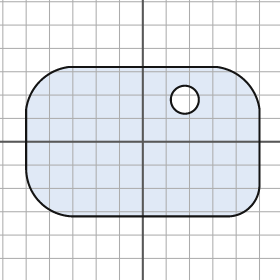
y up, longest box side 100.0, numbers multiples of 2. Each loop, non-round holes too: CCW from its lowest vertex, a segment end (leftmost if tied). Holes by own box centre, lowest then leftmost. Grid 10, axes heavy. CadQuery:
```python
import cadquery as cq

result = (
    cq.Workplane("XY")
    .moveTo(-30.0, -32.0)
    .lineTo(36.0, -32.0)
    .threePointArc((46.0, -28.0), (50.0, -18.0))
    .lineTo(50.0, 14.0)
    .threePointArc((44.0, 26.0), (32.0, 32.0))
    .lineTo(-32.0, 32.0)
    .threePointArc((-44.0, 26.0), (-50.0, 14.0))
    .lineTo(-50.0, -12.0)
    .threePointArc((-44.0, -26.0), (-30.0, -32.0))
    .close()
    .moveTo(18.0, 18.0)
    .circle(6.0)
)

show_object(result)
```